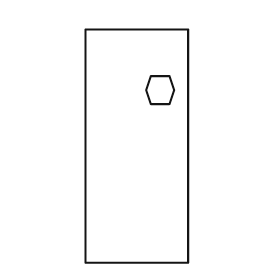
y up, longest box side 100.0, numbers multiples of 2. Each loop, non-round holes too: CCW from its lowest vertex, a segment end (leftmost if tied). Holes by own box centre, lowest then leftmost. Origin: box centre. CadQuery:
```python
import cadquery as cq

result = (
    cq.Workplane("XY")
    .moveTo(-22.0, -50.0)
    .lineTo(22.0, -50.0)
    .lineTo(22.0, 50.0)
    .lineTo(-22.0, 50.0)
    .close()
    .moveTo(6.0, 18.0)
    .lineTo(14.0, 18.0)
    .lineTo(16.0, 24.0)
    .lineTo(14.0, 30.0)
    .lineTo(6.0, 30.0)
    .lineTo(4.0, 24.0)
    .close()
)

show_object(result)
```